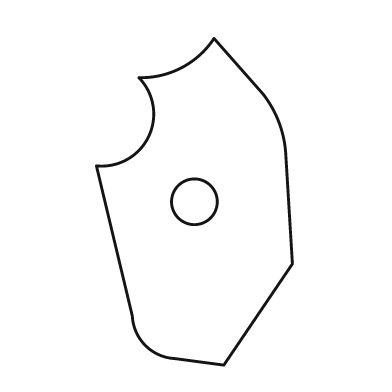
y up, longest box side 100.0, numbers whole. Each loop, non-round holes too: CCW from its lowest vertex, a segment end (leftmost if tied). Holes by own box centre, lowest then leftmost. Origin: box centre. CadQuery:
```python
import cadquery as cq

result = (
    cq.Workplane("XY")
    .moveTo(9.0, -50.0)
    .lineTo(30.0, -19.0)
    .lineTo(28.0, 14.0)
    .threePointArc((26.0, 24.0), (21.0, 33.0))
    .lineTo(6.0, 50.0)
    .threePointArc((-4.0, 41.0), (-17.0, 38.0))
    .threePointArc((-14.0, 20.0), (-30.0, 11.0))
    .lineTo(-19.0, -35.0)
    .threePointArc((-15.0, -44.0), (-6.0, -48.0))
    .close()
    .moveTo(0.0, 0.0)
    .circle(7.0)
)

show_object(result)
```